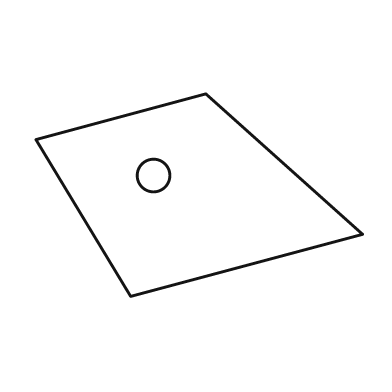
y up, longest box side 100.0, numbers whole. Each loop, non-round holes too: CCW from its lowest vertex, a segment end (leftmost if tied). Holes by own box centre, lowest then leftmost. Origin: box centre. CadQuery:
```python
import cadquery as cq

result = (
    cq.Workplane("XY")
    .moveTo(-21.0, -31.0)
    .lineTo(50.0, -12.0)
    .lineTo(2.0, 31.0)
    .lineTo(-50.0, 17.0)
    .close()
    .moveTo(-14.0, 6.0)
    .circle(5.0)
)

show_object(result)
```